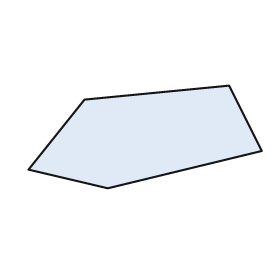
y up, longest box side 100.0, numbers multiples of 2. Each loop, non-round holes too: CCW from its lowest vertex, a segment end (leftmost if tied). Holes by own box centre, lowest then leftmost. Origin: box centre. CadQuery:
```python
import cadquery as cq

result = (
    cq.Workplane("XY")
    .moveTo(-16.0, -22.0)
    .lineTo(50.0, -6.0)
    .lineTo(36.0, 22.0)
    .lineTo(-26.0, 16.0)
    .lineTo(-50.0, -14.0)
    .close()
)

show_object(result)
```